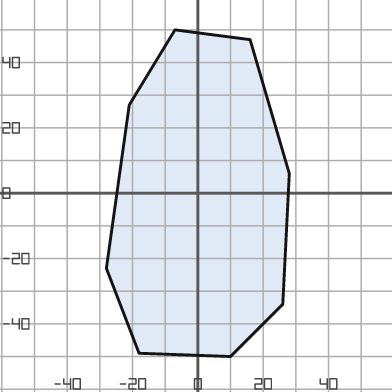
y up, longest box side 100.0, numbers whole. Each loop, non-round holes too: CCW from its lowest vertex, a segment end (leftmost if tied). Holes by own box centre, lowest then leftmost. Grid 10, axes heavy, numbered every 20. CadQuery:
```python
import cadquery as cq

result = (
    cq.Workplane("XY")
    .moveTo(10.0, -50.0)
    .lineTo(26.0, -34.0)
    .lineTo(28.0, 6.0)
    .lineTo(16.0, 47.0)
    .lineTo(-7.0, 50.0)
    .lineTo(-21.0, 27.0)
    .lineTo(-28.0, -23.0)
    .lineTo(-18.0, -49.0)
    .close()
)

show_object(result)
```